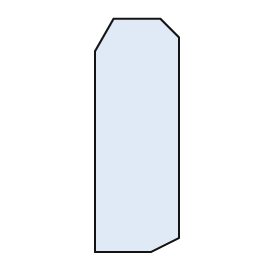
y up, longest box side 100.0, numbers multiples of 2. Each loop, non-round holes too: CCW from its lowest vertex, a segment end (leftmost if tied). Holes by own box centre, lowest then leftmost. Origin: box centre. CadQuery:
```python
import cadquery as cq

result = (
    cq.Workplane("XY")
    .moveTo(-18.0, -50.0)
    .lineTo(6.0, -50.0)
    .lineTo(18.0, -44.0)
    .lineTo(18.0, 42.0)
    .lineTo(10.0, 50.0)
    .lineTo(-10.0, 50.0)
    .lineTo(-18.0, 36.0)
    .close()
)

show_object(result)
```